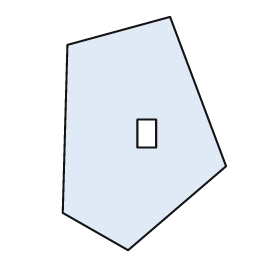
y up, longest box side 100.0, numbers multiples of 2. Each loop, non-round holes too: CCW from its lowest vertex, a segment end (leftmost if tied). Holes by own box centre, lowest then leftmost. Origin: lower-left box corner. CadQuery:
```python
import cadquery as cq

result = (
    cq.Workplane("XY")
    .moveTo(28.0, 0.0)
    .lineTo(70.0, 36.0)
    .lineTo(46.0, 100.0)
    .lineTo(2.0, 88.0)
    .lineTo(0.0, 16.0)
    .close()
    .moveTo(32.0, 44.0)
    .lineTo(40.0, 44.0)
    .lineTo(40.0, 56.0)
    .lineTo(32.0, 56.0)
    .close()
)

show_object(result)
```